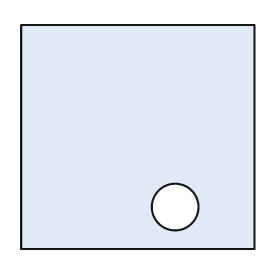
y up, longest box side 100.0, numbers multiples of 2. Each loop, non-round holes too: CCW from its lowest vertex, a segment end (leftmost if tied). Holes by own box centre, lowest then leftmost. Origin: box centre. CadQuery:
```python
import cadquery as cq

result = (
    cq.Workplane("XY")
    .moveTo(-50.0, -48.0)
    .lineTo(50.0, -48.0)
    .lineTo(50.0, 48.0)
    .lineTo(-50.0, 48.0)
    .close()
    .moveTo(16.0, -30.0)
    .circle(10.0)
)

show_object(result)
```